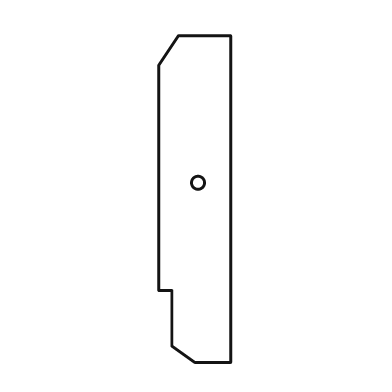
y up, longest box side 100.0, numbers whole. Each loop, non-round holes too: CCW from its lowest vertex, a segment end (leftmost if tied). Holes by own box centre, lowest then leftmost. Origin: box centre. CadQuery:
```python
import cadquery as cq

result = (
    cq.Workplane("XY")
    .moveTo(0.0, -50.0)
    .lineTo(11.0, -50.0)
    .lineTo(11.0, 50.0)
    .lineTo(-5.0, 50.0)
    .lineTo(-11.0, 41.0)
    .lineTo(-11.0, -28.0)
    .lineTo(-7.0, -28.0)
    .lineTo(-7.0, -45.0)
    .close()
    .moveTo(1.0, 5.0)
    .circle(2.0)
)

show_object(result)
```